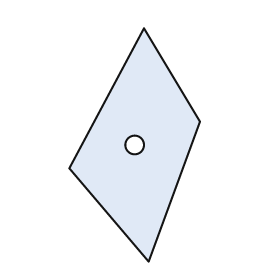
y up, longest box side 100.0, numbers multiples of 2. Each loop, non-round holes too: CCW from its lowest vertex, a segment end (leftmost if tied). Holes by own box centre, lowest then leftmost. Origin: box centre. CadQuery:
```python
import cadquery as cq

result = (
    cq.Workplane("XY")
    .moveTo(6.0, -50.0)
    .lineTo(28.0, 10.0)
    .lineTo(4.0, 50.0)
    .lineTo(-28.0, -10.0)
    .close()
    .moveTo(0.0, 0.0)
    .circle(4.0)
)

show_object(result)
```